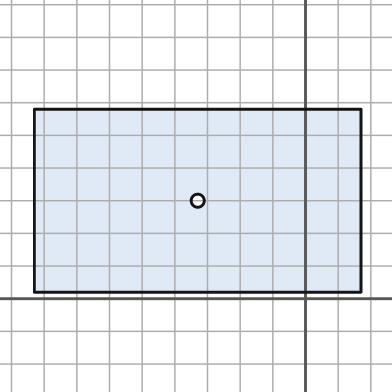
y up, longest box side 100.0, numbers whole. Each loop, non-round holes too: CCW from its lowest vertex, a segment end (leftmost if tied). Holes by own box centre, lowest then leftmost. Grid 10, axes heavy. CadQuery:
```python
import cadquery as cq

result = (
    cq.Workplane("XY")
    .moveTo(-83.0, 2.0)
    .lineTo(17.0, 2.0)
    .lineTo(17.0, 58.0)
    .lineTo(-83.0, 58.0)
    .close()
    .moveTo(-33.0, 30.0)
    .circle(2.0)
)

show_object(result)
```